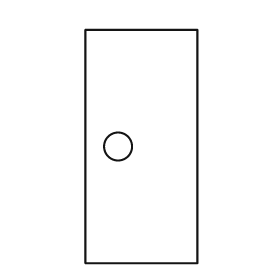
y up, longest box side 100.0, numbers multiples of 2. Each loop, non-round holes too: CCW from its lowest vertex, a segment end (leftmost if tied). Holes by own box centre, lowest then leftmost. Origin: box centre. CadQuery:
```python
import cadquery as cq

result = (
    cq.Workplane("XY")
    .moveTo(-24.0, -50.0)
    .lineTo(24.0, -50.0)
    .lineTo(24.0, 50.0)
    .lineTo(-24.0, 50.0)
    .close()
    .moveTo(-10.0, 0.0)
    .circle(6.0)
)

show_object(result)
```